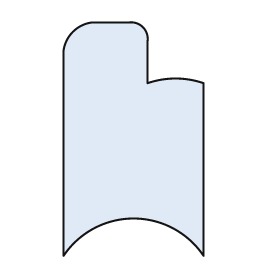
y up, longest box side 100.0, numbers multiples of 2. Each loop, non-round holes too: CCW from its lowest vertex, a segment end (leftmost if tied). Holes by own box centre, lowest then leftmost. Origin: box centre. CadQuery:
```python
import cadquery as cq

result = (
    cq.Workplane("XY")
    .moveTo(-30.0, -50.0)
    .threePointArc((0.0, -34.0), (30.0, -50.0))
    .lineTo(30.0, 24.0)
    .threePointArc((18.0, 26.0), (6.0, 24.0))
    .lineTo(6.0, 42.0)
    .threePointArc((4.0, 48.0), (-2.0, 50.0))
    .lineTo(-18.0, 50.0)
    .threePointArc((-26.0, 46.0), (-30.0, 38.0))
    .close()
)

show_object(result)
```